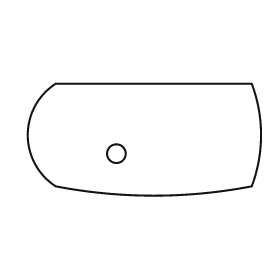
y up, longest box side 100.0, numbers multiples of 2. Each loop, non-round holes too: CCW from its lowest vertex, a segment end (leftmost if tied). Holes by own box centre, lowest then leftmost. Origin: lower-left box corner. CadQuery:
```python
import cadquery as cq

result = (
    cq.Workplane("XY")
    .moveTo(12.0, 4.0)
    .threePointArc((54.0, 0.0), (96.0, 4.0))
    .threePointArc((100.0, 26.0), (96.0, 48.0))
    .lineTo(12.0, 48.0)
    .threePointArc((0.0, 26.0), (12.0, 4.0))
    .close()
    .moveTo(38.0, 18.0)
    .circle(4.0)
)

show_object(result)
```